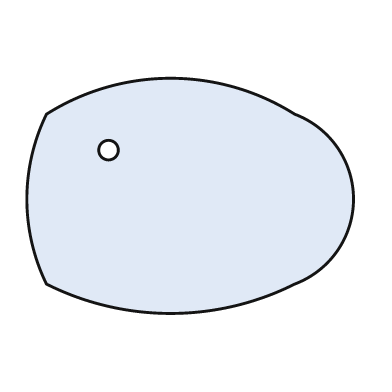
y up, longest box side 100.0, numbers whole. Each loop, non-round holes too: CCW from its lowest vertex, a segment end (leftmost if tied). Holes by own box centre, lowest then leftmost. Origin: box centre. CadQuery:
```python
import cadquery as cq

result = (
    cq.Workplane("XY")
    .moveTo(-44.0, -27.0)
    .threePointArc((-6.0, -36.0), (32.0, -27.0))
    .threePointArc((50.0, -1.0), (32.0, 25.0))
    .threePointArc((-6.0, 36.0), (-44.0, 25.0))
    .threePointArc((-50.0, -1.0), (-44.0, -27.0))
    .close()
    .moveTo(-25.0, 14.0)
    .circle(3.0)
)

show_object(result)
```